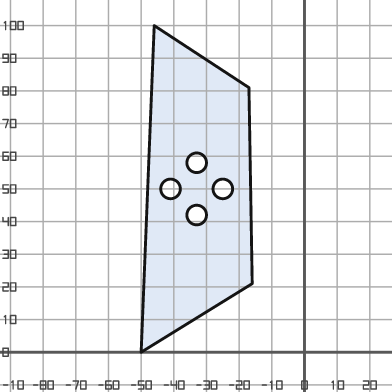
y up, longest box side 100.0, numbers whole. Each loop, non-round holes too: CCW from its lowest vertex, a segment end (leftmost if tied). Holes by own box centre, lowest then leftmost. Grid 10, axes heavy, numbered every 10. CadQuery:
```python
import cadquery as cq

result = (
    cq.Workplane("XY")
    .moveTo(-50.0, 0.0)
    .lineTo(-16.0, 21.0)
    .lineTo(-17.0, 81.0)
    .lineTo(-46.0, 100.0)
    .close()
    .moveTo(-33.0, 42.0)
    .circle(3.0)
    .moveTo(-41.0, 50.0)
    .circle(3.0)
    .moveTo(-25.0, 50.0)
    .circle(3.0)
    .moveTo(-33.0, 58.0)
    .circle(3.0)
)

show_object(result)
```